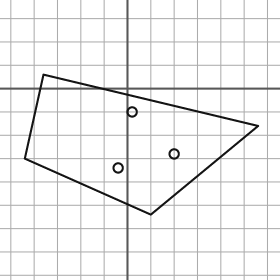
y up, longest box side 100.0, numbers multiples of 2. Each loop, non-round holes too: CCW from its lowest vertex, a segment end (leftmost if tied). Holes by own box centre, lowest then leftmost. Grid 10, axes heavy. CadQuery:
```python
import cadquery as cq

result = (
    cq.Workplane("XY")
    .moveTo(10.0, -54.0)
    .lineTo(56.0, -16.0)
    .lineTo(-36.0, 6.0)
    .lineTo(-44.0, -30.0)
    .close()
    .moveTo(-4.0, -34.0)
    .circle(2.0)
    .moveTo(20.0, -28.0)
    .circle(2.0)
    .moveTo(2.0, -10.0)
    .circle(2.0)
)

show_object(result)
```